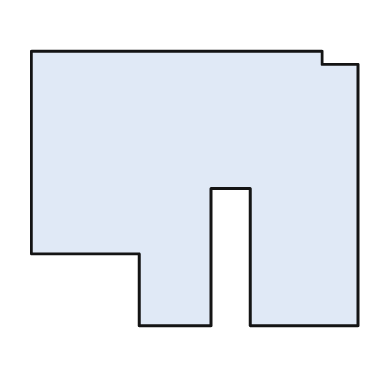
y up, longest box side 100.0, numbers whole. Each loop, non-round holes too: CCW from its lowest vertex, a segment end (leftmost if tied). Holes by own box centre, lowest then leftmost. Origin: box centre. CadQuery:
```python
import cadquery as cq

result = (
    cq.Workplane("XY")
    .moveTo(-17.0, -42.0)
    .lineTo(5.0, -42.0)
    .lineTo(5.0, 0.0)
    .lineTo(17.0, 0.0)
    .lineTo(17.0, -42.0)
    .lineTo(50.0, -42.0)
    .lineTo(50.0, 38.0)
    .lineTo(39.0, 38.0)
    .lineTo(39.0, 42.0)
    .lineTo(-50.0, 42.0)
    .lineTo(-50.0, -20.0)
    .lineTo(-17.0, -20.0)
    .close()
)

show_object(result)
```